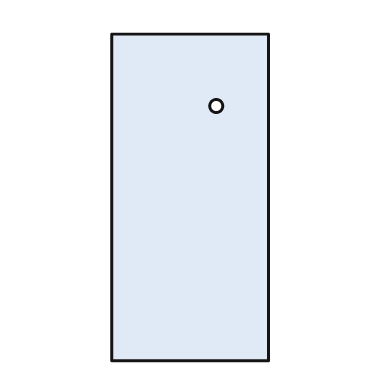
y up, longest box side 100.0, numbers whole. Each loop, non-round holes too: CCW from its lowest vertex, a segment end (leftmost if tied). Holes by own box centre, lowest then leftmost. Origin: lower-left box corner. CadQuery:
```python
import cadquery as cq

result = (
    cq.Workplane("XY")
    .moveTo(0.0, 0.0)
    .lineTo(48.0, 0.0)
    .lineTo(48.0, 100.0)
    .lineTo(0.0, 100.0)
    .close()
    .moveTo(32.0, 78.0)
    .circle(2.0)
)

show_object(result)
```